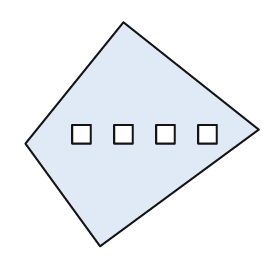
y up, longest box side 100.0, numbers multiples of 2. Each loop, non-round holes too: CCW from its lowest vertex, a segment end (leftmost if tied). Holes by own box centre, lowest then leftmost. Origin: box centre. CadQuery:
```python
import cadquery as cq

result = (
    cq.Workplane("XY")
    .moveTo(-18.0, -48.0)
    .lineTo(50.0, 2.0)
    .lineTo(-8.0, 48.0)
    .lineTo(-50.0, -4.0)
    .close()
    .moveTo(-30.0, -4.0)
    .lineTo(-22.0, -4.0)
    .lineTo(-22.0, 4.0)
    .lineTo(-30.0, 4.0)
    .close()
    .moveTo(-12.0, -4.0)
    .lineTo(-4.0, -4.0)
    .lineTo(-4.0, 4.0)
    .lineTo(-12.0, 4.0)
    .close()
    .moveTo(6.0, -4.0)
    .lineTo(14.0, -4.0)
    .lineTo(14.0, 4.0)
    .lineTo(6.0, 4.0)
    .close()
    .moveTo(24.0, -4.0)
    .lineTo(32.0, -4.0)
    .lineTo(32.0, 4.0)
    .lineTo(24.0, 4.0)
    .close()
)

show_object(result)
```